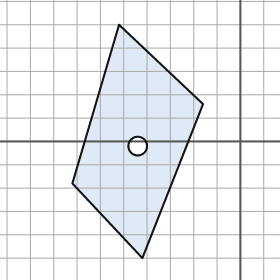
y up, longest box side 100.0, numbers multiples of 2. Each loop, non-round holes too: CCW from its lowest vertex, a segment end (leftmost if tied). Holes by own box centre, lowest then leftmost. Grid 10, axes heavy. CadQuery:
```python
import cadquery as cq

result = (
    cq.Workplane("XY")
    .moveTo(-42.0, -50.0)
    .lineTo(-16.0, 16.0)
    .lineTo(-52.0, 50.0)
    .lineTo(-72.0, -18.0)
    .close()
    .moveTo(-44.0, -2.0)
    .circle(4.0)
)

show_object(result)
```